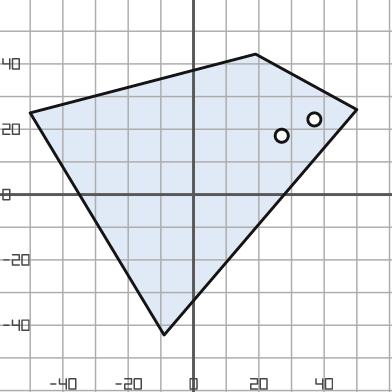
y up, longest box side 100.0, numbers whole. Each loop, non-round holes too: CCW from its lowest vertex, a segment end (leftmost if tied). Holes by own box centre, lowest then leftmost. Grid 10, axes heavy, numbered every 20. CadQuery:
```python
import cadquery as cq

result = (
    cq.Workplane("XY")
    .moveTo(-9.0, -43.0)
    .lineTo(50.0, 26.0)
    .lineTo(19.0, 43.0)
    .lineTo(-50.0, 25.0)
    .close()
    .moveTo(27.0, 18.0)
    .circle(2.0)
    .moveTo(37.0, 23.0)
    .circle(2.0)
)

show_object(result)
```